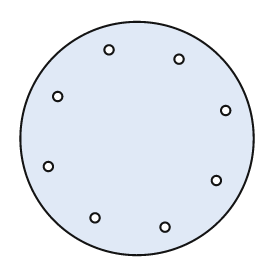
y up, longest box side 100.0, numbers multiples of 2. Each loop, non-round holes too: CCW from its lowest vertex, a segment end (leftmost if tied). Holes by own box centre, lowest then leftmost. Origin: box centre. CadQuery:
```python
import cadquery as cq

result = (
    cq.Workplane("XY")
    .moveTo(0.0, 0.0)
    .circle(50.0)
    .moveTo(12.0, -38.0)
    .circle(2.0)
    .moveTo(-18.0, -34.0)
    .circle(2.0)
    .moveTo(34.0, -18.0)
    .circle(2.0)
    .moveTo(-38.0, -12.0)
    .circle(2.0)
    .moveTo(38.0, 12.0)
    .circle(2.0)
    .moveTo(-34.0, 18.0)
    .circle(2.0)
    .moveTo(18.0, 34.0)
    .circle(2.0)
    .moveTo(-12.0, 38.0)
    .circle(2.0)
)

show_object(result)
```